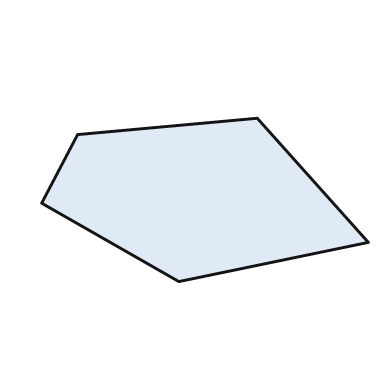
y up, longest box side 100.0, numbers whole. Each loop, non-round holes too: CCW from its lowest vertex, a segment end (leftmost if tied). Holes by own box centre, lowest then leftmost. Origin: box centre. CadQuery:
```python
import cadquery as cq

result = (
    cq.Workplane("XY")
    .moveTo(-8.0, -25.0)
    .lineTo(50.0, -13.0)
    .lineTo(16.0, 25.0)
    .lineTo(-39.0, 20.0)
    .lineTo(-50.0, -1.0)
    .close()
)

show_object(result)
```